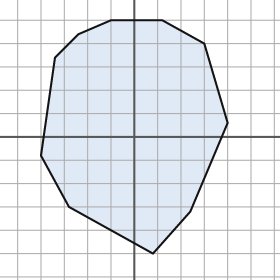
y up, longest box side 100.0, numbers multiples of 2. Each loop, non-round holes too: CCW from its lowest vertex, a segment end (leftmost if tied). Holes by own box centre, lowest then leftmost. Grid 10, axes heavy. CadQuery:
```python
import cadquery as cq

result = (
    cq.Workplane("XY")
    .moveTo(8.0, -50.0)
    .lineTo(24.0, -32.0)
    .lineTo(40.0, 6.0)
    .lineTo(30.0, 40.0)
    .lineTo(12.0, 50.0)
    .lineTo(-10.0, 50.0)
    .lineTo(-24.0, 44.0)
    .lineTo(-34.0, 34.0)
    .lineTo(-40.0, -8.0)
    .lineTo(-28.0, -30.0)
    .close()
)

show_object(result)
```